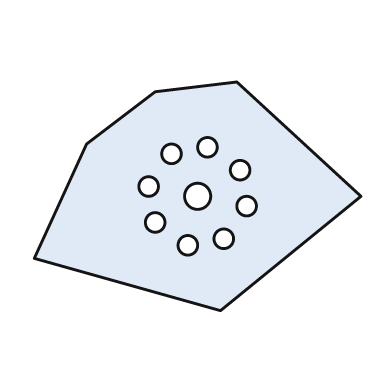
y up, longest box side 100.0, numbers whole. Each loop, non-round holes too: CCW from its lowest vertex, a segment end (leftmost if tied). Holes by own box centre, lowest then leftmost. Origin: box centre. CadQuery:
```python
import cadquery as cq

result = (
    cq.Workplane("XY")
    .moveTo(7.0, -35.0)
    .lineTo(50.0, 0.0)
    .lineTo(12.0, 35.0)
    .lineTo(-13.0, 32.0)
    .lineTo(-34.0, 16.0)
    .lineTo(-50.0, -19.0)
    .close()
    .moveTo(-3.0, -15.0)
    .circle(3.0)
    .moveTo(8.0, -13.0)
    .circle(3.0)
    .moveTo(-13.0, -8.0)
    .circle(3.0)
    .moveTo(15.0, -3.0)
    .circle(3.0)
    .moveTo(0.0, 0.0)
    .circle(4.0)
    .moveTo(-15.0, 3.0)
    .circle(3.0)
    .moveTo(13.0, 8.0)
    .circle(3.0)
    .moveTo(-8.0, 13.0)
    .circle(3.0)
    .moveTo(3.0, 15.0)
    .circle(3.0)
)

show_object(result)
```